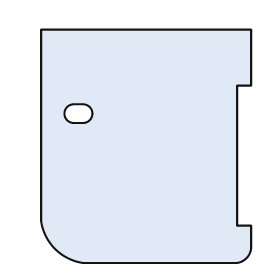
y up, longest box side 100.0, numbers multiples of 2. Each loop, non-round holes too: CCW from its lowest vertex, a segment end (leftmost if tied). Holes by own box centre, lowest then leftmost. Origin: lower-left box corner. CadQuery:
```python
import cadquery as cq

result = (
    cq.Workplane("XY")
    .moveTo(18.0, 0.0)
    .lineTo(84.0, 0.0)
    .threePointArc((88.0, 2.0), (90.0, 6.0))
    .lineTo(90.0, 16.0)
    .lineTo(84.0, 16.0)
    .lineTo(84.0, 76.0)
    .lineTo(90.0, 76.0)
    .lineTo(90.0, 100.0)
    .lineTo(0.0, 100.0)
    .lineTo(0.0, 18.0)
    .threePointArc((6.0, 6.0), (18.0, 0.0))
    .close()
    .moveTo(14.0, 60.0)
    .lineTo(18.0, 60.0)
    .threePointArc((22.0, 64.0), (18.0, 68.0))
    .lineTo(14.0, 68.0)
    .threePointArc((10.0, 64.0), (14.0, 60.0))
    .close()
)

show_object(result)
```